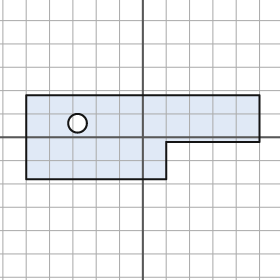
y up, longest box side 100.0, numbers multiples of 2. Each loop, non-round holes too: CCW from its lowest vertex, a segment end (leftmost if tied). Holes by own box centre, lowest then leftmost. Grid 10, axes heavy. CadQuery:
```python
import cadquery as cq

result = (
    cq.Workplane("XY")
    .moveTo(-50.0, -18.0)
    .lineTo(10.0, -18.0)
    .lineTo(10.0, -2.0)
    .lineTo(50.0, -2.0)
    .lineTo(50.0, 18.0)
    .lineTo(-50.0, 18.0)
    .close()
    .moveTo(-28.0, 6.0)
    .circle(4.0)
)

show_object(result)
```